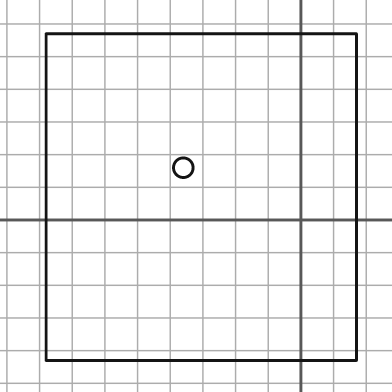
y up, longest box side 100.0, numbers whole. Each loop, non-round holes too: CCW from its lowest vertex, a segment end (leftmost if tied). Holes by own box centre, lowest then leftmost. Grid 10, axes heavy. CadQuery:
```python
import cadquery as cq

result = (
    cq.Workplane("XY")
    .moveTo(-78.0, -43.0)
    .lineTo(17.0, -43.0)
    .lineTo(17.0, 57.0)
    .lineTo(-78.0, 57.0)
    .close()
    .moveTo(-36.0, 16.0)
    .circle(3.0)
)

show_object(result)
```